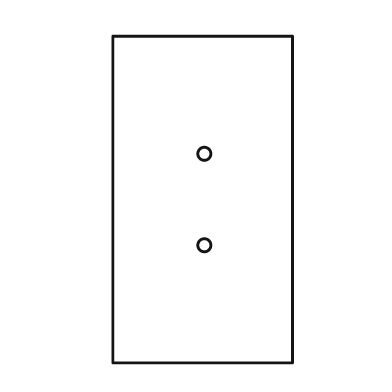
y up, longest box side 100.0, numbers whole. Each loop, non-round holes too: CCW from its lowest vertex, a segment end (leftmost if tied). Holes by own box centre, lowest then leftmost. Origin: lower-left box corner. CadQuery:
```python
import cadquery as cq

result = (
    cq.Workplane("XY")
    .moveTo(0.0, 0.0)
    .lineTo(55.0, 0.0)
    .lineTo(55.0, 100.0)
    .lineTo(0.0, 100.0)
    .close()
    .moveTo(28.0, 36.0)
    .circle(2.0)
    .moveTo(28.0, 64.0)
    .circle(2.0)
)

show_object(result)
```